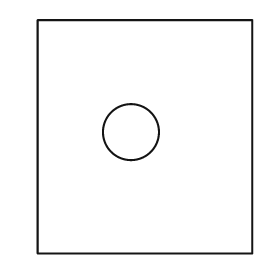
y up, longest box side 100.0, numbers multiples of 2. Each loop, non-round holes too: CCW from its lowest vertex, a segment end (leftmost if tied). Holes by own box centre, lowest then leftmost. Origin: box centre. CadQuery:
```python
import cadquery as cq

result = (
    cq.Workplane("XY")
    .moveTo(-46.0, -50.0)
    .lineTo(46.0, -50.0)
    .lineTo(46.0, 50.0)
    .lineTo(-46.0, 50.0)
    .close()
    .moveTo(-6.0, 2.0)
    .circle(12.0)
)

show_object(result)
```